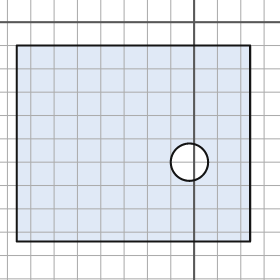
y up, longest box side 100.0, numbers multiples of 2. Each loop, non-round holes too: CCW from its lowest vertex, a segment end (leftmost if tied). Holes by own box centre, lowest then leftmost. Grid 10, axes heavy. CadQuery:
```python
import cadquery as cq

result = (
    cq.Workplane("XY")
    .moveTo(-76.0, -94.0)
    .lineTo(24.0, -94.0)
    .lineTo(24.0, -10.0)
    .lineTo(-76.0, -10.0)
    .close()
    .moveTo(-2.0, -60.0)
    .circle(8.0)
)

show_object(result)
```